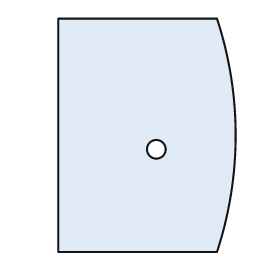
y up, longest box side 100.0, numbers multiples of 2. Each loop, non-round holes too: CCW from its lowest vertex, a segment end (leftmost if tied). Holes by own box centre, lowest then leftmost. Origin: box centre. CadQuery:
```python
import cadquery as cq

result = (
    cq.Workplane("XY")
    .moveTo(-38.0, -50.0)
    .lineTo(30.0, -50.0)
    .threePointArc((38.0, 0.0), (30.0, 50.0))
    .lineTo(-38.0, 50.0)
    .close()
    .moveTo(4.0, -6.0)
    .circle(4.0)
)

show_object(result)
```